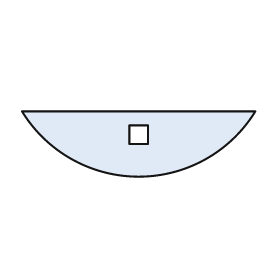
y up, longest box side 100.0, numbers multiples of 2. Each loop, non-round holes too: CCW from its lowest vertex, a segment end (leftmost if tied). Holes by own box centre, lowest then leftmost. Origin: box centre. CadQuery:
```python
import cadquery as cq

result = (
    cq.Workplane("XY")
    .moveTo(-50.0, 14.0)
    .threePointArc((0.0, -14.0), (50.0, 14.0))
    .close()
    .moveTo(-4.0, 0.0)
    .lineTo(4.0, 0.0)
    .lineTo(4.0, 8.0)
    .lineTo(-4.0, 8.0)
    .close()
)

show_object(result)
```